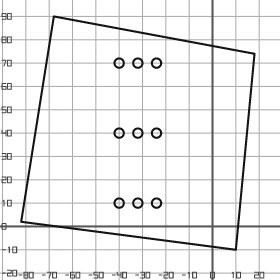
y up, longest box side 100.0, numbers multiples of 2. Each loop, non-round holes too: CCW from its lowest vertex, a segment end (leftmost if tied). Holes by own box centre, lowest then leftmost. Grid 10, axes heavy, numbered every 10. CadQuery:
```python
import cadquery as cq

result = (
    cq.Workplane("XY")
    .moveTo(10.0, -10.0)
    .lineTo(18.0, 74.0)
    .lineTo(-68.0, 90.0)
    .lineTo(-82.0, 2.0)
    .close()
    .moveTo(-40.0, 10.0)
    .circle(2.0)
    .moveTo(-32.0, 10.0)
    .circle(2.0)
    .moveTo(-24.0, 10.0)
    .circle(2.0)
    .moveTo(-40.0, 40.0)
    .circle(2.0)
    .moveTo(-32.0, 40.0)
    .circle(2.0)
    .moveTo(-24.0, 40.0)
    .circle(2.0)
    .moveTo(-40.0, 70.0)
    .circle(2.0)
    .moveTo(-32.0, 70.0)
    .circle(2.0)
    .moveTo(-24.0, 70.0)
    .circle(2.0)
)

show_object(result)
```